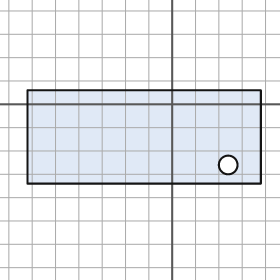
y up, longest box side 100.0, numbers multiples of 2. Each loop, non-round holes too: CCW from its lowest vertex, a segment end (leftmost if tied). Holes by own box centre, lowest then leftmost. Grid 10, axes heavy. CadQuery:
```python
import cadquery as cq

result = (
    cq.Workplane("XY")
    .moveTo(-62.0, -34.0)
    .lineTo(38.0, -34.0)
    .lineTo(38.0, 6.0)
    .lineTo(-62.0, 6.0)
    .close()
    .moveTo(24.0, -26.0)
    .circle(4.0)
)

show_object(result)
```